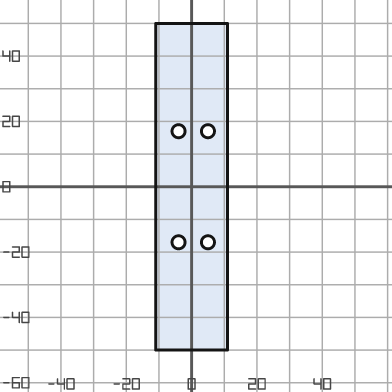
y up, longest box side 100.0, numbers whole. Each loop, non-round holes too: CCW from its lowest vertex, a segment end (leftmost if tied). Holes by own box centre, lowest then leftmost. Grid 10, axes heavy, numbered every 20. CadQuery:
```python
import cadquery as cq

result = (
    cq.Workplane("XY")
    .moveTo(-11.0, -50.0)
    .lineTo(11.0, -50.0)
    .lineTo(11.0, 50.0)
    .lineTo(-11.0, 50.0)
    .close()
    .moveTo(-4.0, -17.0)
    .circle(2.0)
    .moveTo(5.0, -17.0)
    .circle(2.0)
    .moveTo(-4.0, 17.0)
    .circle(2.0)
    .moveTo(5.0, 17.0)
    .circle(2.0)
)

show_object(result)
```